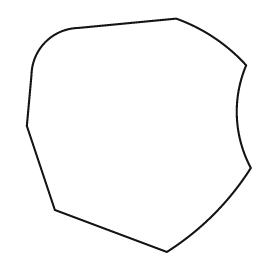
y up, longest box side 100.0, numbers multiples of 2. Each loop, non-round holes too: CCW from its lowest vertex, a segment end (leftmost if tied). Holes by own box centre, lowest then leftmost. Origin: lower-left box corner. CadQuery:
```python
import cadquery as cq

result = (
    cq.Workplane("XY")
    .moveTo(60.0, 0.0)
    .threePointArc((80.0, 16.0), (96.0, 36.0))
    .threePointArc((90.0, 58.0), (94.0, 80.0))
    .threePointArc((80.0, 92.0), (64.0, 100.0))
    .lineTo(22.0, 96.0)
    .threePointArc((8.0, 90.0), (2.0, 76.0))
    .lineTo(0.0, 54.0)
    .lineTo(12.0, 18.0)
    .close()
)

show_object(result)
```